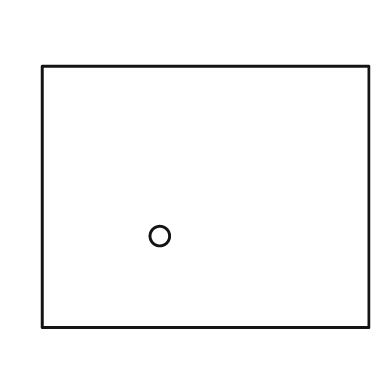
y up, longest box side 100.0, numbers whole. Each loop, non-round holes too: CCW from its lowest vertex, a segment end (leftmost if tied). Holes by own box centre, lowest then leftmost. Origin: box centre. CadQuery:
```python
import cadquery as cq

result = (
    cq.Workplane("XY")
    .moveTo(-50.0, -40.0)
    .lineTo(50.0, -40.0)
    .lineTo(50.0, 40.0)
    .lineTo(-50.0, 40.0)
    .close()
    .moveTo(-14.0, -12.0)
    .circle(3.0)
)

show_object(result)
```